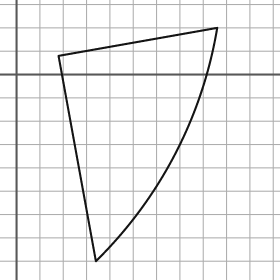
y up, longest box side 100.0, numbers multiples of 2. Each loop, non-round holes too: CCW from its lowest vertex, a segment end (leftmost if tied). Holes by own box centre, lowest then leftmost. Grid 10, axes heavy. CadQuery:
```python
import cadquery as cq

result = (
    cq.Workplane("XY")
    .moveTo(34.0, -80.0)
    .threePointArc((68.0, -34.0), (86.0, 20.0))
    .lineTo(18.0, 8.0)
    .close()
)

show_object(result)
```